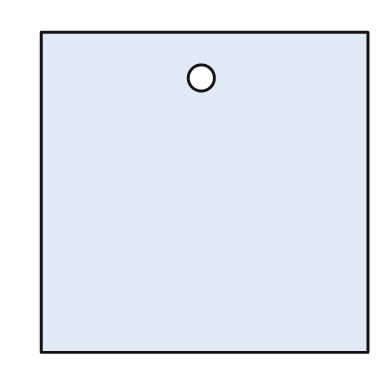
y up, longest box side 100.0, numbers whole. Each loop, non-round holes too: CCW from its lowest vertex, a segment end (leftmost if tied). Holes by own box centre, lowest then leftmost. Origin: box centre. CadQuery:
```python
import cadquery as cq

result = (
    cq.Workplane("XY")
    .moveTo(-50.0, -49.0)
    .lineTo(50.0, -49.0)
    .lineTo(50.0, 49.0)
    .lineTo(-50.0, 49.0)
    .close()
    .moveTo(-1.0, 35.0)
    .circle(4.0)
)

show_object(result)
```